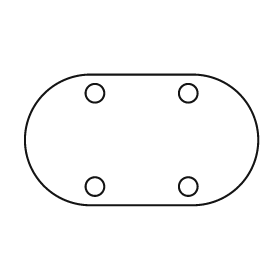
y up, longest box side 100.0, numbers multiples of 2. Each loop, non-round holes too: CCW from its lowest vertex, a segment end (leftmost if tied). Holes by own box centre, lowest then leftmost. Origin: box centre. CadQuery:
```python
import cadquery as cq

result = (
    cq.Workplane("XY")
    .moveTo(-22.0, -28.0)
    .lineTo(22.0, -28.0)
    .threePointArc((50.0, 0.0), (22.0, 28.0))
    .lineTo(-22.0, 28.0)
    .threePointArc((-50.0, 0.0), (-22.0, -28.0))
    .close()
    .moveTo(-20.0, -20.0)
    .circle(4.0)
    .moveTo(20.0, -20.0)
    .circle(4.0)
    .moveTo(-20.0, 20.0)
    .circle(4.0)
    .moveTo(20.0, 20.0)
    .circle(4.0)
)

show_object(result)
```